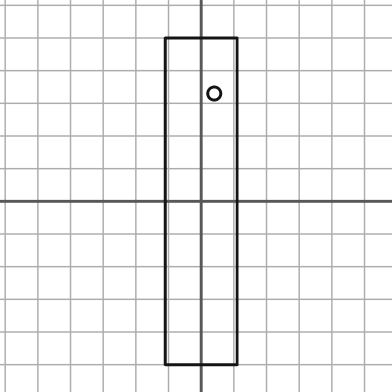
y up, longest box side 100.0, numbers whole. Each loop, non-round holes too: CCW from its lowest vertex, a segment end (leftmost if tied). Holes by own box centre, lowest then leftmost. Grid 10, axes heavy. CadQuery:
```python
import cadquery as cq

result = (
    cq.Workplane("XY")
    .moveTo(-11.0, -50.0)
    .lineTo(11.0, -50.0)
    .lineTo(11.0, 50.0)
    .lineTo(-11.0, 50.0)
    .close()
    .moveTo(4.0, 33.0)
    .circle(2.0)
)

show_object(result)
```